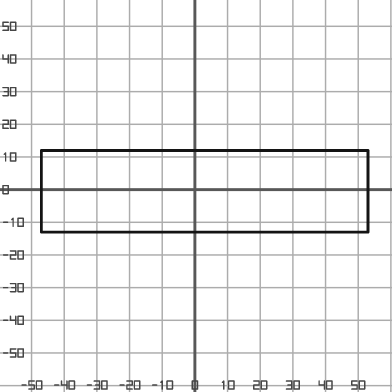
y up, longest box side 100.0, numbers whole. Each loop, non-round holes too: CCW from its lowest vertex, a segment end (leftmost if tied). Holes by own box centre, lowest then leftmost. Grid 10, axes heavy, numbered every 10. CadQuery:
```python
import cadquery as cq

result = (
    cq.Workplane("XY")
    .moveTo(-47.0, -13.0)
    .lineTo(53.0, -13.0)
    .lineTo(53.0, 12.0)
    .lineTo(-47.0, 12.0)
    .close()
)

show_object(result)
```